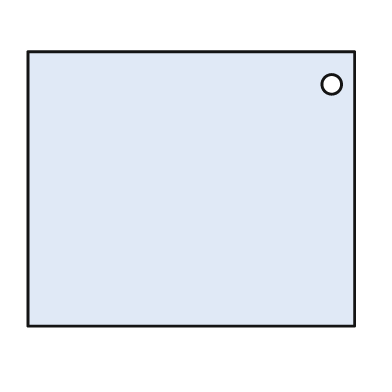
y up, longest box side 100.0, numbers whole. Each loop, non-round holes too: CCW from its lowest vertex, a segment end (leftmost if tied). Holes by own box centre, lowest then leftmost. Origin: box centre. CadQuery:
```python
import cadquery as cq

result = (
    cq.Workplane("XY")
    .moveTo(-50.0, -42.0)
    .lineTo(50.0, -42.0)
    .lineTo(50.0, 42.0)
    .lineTo(-50.0, 42.0)
    .close()
    .moveTo(43.0, 32.0)
    .circle(3.0)
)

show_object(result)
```